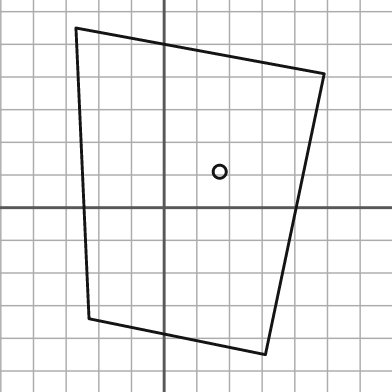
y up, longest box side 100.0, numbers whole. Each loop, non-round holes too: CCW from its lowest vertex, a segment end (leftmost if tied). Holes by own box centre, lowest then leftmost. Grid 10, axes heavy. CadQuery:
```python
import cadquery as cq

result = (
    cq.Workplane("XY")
    .moveTo(31.0, -45.0)
    .lineTo(49.0, 41.0)
    .lineTo(-27.0, 55.0)
    .lineTo(-23.0, -34.0)
    .close()
    .moveTo(17.0, 11.0)
    .circle(2.0)
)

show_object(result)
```